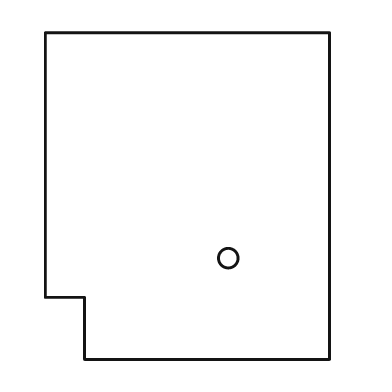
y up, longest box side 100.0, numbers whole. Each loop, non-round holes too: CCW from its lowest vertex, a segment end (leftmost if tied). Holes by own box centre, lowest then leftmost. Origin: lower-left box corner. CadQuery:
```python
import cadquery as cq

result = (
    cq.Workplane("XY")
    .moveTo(12.0, 0.0)
    .lineTo(87.0, 0.0)
    .lineTo(87.0, 100.0)
    .lineTo(0.0, 100.0)
    .lineTo(0.0, 19.0)
    .lineTo(12.0, 19.0)
    .close()
    .moveTo(56.0, 31.0)
    .circle(3.0)
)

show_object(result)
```